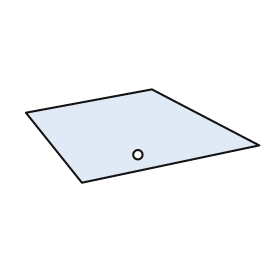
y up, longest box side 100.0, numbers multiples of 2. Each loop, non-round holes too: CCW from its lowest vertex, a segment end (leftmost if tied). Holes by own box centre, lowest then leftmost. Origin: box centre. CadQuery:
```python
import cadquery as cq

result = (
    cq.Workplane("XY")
    .moveTo(-26.0, -20.0)
    .lineTo(50.0, -4.0)
    .lineTo(4.0, 20.0)
    .lineTo(-50.0, 10.0)
    .close()
    .moveTo(-2.0, -8.0)
    .circle(2.0)
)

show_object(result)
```